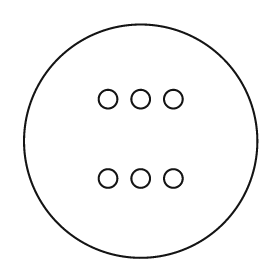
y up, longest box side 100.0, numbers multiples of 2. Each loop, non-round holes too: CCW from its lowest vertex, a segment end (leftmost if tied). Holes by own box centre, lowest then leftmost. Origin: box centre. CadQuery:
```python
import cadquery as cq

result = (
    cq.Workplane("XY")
    .moveTo(0.0, 0.0)
    .circle(50.0)
    .moveTo(-14.0, -16.0)
    .circle(4.0)
    .moveTo(0.0, -16.0)
    .circle(4.0)
    .moveTo(14.0, -16.0)
    .circle(4.0)
    .moveTo(-14.0, 18.0)
    .circle(4.0)
    .moveTo(0.0, 18.0)
    .circle(4.0)
    .moveTo(14.0, 18.0)
    .circle(4.0)
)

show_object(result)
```